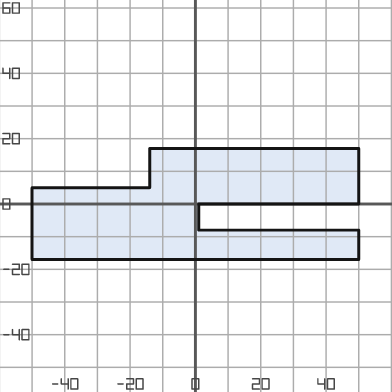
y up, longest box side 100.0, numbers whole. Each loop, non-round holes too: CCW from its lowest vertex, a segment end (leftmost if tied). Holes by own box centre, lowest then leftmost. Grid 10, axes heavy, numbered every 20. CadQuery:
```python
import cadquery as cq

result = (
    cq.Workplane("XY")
    .moveTo(-50.0, -17.0)
    .lineTo(50.0, -17.0)
    .lineTo(50.0, -8.0)
    .lineTo(1.0, -8.0)
    .lineTo(1.0, 0.0)
    .lineTo(50.0, 0.0)
    .lineTo(50.0, 17.0)
    .lineTo(-14.0, 17.0)
    .lineTo(-14.0, 5.0)
    .lineTo(-50.0, 5.0)
    .close()
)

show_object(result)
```